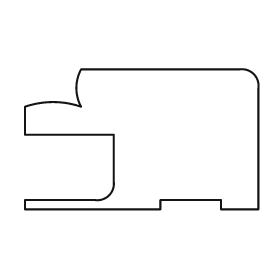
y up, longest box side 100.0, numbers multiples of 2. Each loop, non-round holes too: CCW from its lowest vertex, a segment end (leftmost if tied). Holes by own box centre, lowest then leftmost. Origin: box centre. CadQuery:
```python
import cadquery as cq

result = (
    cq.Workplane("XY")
    .moveTo(-50.0, -30.0)
    .lineTo(8.0, -30.0)
    .lineTo(8.0, -26.0)
    .lineTo(34.0, -26.0)
    .lineTo(34.0, -30.0)
    .lineTo(50.0, -30.0)
    .lineTo(50.0, 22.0)
    .threePointArc((48.0, 28.0), (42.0, 30.0))
    .lineTo(-26.0, 30.0)
    .threePointArc((-28.0, 22.0), (-26.0, 14.0))
    .threePointArc((-38.0, 16.0), (-50.0, 14.0))
    .lineTo(-50.0, 2.0)
    .lineTo(-12.0, 2.0)
    .lineTo(-12.0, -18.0)
    .threePointArc((-14.0, -24.0), (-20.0, -26.0))
    .lineTo(-50.0, -26.0)
    .close()
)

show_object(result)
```